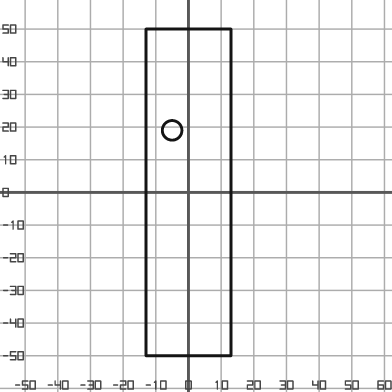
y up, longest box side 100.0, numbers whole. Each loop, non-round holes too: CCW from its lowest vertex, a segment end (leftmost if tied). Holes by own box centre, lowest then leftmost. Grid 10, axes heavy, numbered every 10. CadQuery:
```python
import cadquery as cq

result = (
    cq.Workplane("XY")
    .moveTo(-13.0, -50.0)
    .lineTo(13.0, -50.0)
    .lineTo(13.0, 50.0)
    .lineTo(-13.0, 50.0)
    .close()
    .moveTo(-5.0, 19.0)
    .circle(3.0)
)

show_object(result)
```